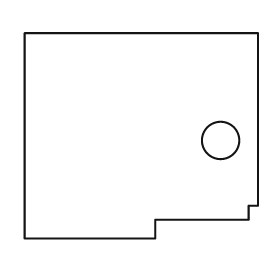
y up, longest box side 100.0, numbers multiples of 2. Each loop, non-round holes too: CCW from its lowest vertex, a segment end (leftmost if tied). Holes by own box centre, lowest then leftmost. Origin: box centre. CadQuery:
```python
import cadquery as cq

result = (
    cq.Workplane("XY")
    .moveTo(-50.0, -44.0)
    .lineTo(6.0, -44.0)
    .lineTo(6.0, -36.0)
    .lineTo(46.0, -36.0)
    .lineTo(46.0, -30.0)
    .lineTo(50.0, -30.0)
    .lineTo(50.0, 44.0)
    .lineTo(-50.0, 44.0)
    .close()
    .moveTo(34.0, -2.0)
    .circle(8.0)
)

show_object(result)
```